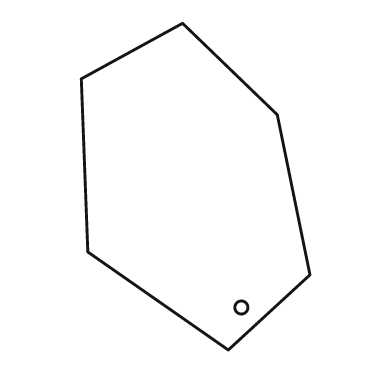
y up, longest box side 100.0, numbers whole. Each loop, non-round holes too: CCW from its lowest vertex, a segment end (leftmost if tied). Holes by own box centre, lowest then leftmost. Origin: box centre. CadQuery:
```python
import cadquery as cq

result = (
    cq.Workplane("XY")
    .moveTo(10.0, -50.0)
    .lineTo(35.0, -27.0)
    .lineTo(25.0, 22.0)
    .lineTo(-4.0, 50.0)
    .lineTo(-35.0, 33.0)
    .lineTo(-33.0, -20.0)
    .close()
    .moveTo(14.0, -37.0)
    .circle(2.0)
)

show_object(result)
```